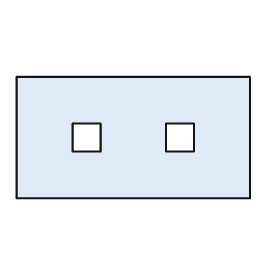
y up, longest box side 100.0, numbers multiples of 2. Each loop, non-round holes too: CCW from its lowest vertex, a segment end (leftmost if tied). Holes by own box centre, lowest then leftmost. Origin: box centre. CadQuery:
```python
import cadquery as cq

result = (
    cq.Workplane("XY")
    .moveTo(-50.0, -26.0)
    .lineTo(50.0, -26.0)
    .lineTo(50.0, 26.0)
    .lineTo(-50.0, 26.0)
    .close()
    .moveTo(-26.0, -6.0)
    .lineTo(-14.0, -6.0)
    .lineTo(-14.0, 6.0)
    .lineTo(-26.0, 6.0)
    .close()
    .moveTo(14.0, -6.0)
    .lineTo(26.0, -6.0)
    .lineTo(26.0, 6.0)
    .lineTo(14.0, 6.0)
    .close()
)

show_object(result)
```